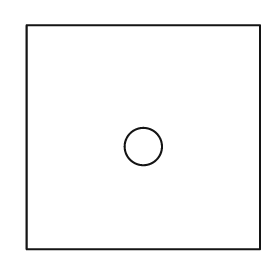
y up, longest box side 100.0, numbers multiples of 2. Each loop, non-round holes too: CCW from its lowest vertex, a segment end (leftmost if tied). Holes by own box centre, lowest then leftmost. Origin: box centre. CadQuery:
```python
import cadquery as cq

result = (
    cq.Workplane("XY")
    .moveTo(-50.0, -48.0)
    .lineTo(50.0, -48.0)
    .lineTo(50.0, 48.0)
    .lineTo(-50.0, 48.0)
    .close()
    .moveTo(0.0, -4.0)
    .circle(8.0)
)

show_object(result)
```